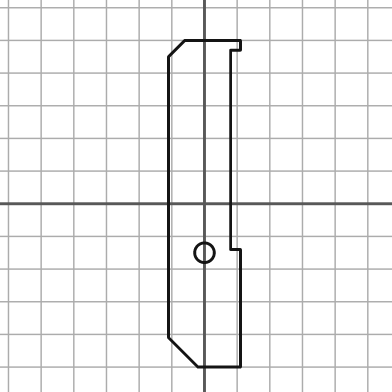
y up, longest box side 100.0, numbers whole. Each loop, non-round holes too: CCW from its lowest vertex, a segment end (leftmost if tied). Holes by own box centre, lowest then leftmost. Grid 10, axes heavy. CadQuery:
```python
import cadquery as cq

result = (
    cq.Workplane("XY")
    .moveTo(-2.0, -50.0)
    .lineTo(11.0, -50.0)
    .lineTo(11.0, -14.0)
    .lineTo(8.0, -14.0)
    .lineTo(8.0, 47.0)
    .lineTo(11.0, 47.0)
    .lineTo(11.0, 50.0)
    .lineTo(-6.0, 50.0)
    .lineTo(-11.0, 45.0)
    .lineTo(-11.0, -41.0)
    .close()
    .moveTo(0.0, -15.0)
    .circle(3.0)
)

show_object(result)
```